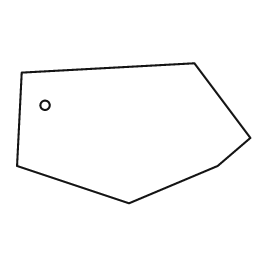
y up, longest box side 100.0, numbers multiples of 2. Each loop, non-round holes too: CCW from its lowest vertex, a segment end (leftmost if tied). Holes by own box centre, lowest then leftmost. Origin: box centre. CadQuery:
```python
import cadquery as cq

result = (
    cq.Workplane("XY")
    .moveTo(-2.0, -30.0)
    .lineTo(36.0, -14.0)
    .lineTo(50.0, -2.0)
    .lineTo(26.0, 30.0)
    .lineTo(-48.0, 26.0)
    .lineTo(-50.0, -14.0)
    .close()
    .moveTo(-38.0, 12.0)
    .circle(2.0)
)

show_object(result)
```